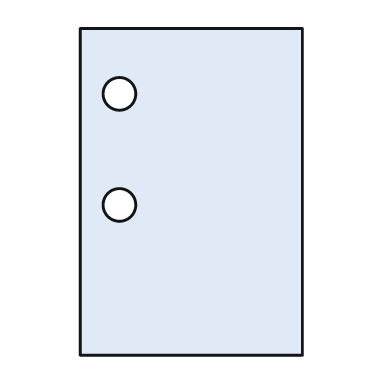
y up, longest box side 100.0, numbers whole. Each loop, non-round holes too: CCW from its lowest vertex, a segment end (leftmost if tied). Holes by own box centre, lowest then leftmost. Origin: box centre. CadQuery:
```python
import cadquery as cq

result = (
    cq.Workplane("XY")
    .moveTo(-34.0, -50.0)
    .lineTo(34.0, -50.0)
    .lineTo(34.0, 50.0)
    .lineTo(-34.0, 50.0)
    .close()
    .moveTo(-22.0, -4.0)
    .circle(5.0)
    .moveTo(-22.0, 30.0)
    .circle(5.0)
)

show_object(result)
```